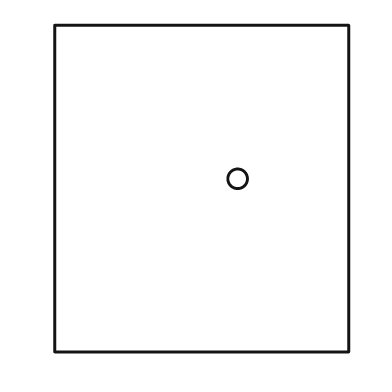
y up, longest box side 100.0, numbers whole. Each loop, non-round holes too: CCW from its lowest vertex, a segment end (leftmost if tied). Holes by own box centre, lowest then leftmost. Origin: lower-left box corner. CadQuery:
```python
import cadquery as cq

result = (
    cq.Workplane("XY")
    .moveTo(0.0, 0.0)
    .lineTo(90.0, 0.0)
    .lineTo(90.0, 100.0)
    .lineTo(0.0, 100.0)
    .close()
    .moveTo(56.0, 53.0)
    .circle(3.0)
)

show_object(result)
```